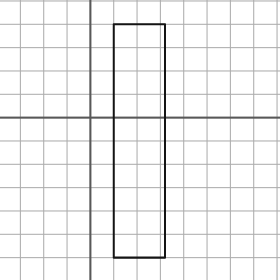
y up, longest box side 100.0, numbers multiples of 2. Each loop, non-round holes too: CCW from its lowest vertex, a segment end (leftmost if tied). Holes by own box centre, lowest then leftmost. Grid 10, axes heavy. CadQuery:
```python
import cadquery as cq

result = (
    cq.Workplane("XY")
    .moveTo(10.0, -60.0)
    .lineTo(32.0, -60.0)
    .lineTo(32.0, 40.0)
    .lineTo(10.0, 40.0)
    .close()
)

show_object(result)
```